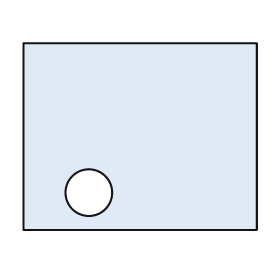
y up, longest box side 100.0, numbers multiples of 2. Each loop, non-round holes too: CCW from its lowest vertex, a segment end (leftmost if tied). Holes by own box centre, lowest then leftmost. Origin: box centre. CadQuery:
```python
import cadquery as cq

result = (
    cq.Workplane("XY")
    .moveTo(-50.0, -40.0)
    .lineTo(50.0, -40.0)
    .lineTo(50.0, 40.0)
    .lineTo(-50.0, 40.0)
    .close()
    .moveTo(-22.0, -24.0)
    .circle(10.0)
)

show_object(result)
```